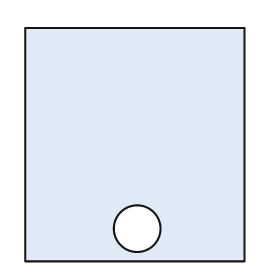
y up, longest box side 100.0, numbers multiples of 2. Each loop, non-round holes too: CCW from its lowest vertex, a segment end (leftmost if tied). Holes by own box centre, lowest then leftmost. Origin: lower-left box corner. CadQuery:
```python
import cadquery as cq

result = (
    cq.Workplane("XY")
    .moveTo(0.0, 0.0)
    .lineTo(94.0, 0.0)
    .lineTo(94.0, 100.0)
    .lineTo(0.0, 100.0)
    .close()
    .moveTo(48.0, 14.0)
    .circle(10.0)
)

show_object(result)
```